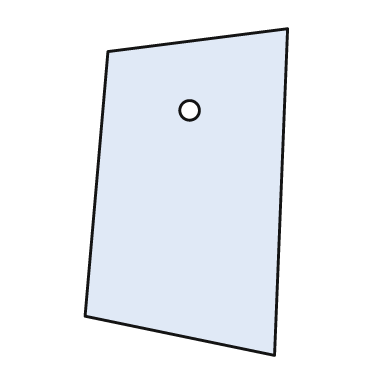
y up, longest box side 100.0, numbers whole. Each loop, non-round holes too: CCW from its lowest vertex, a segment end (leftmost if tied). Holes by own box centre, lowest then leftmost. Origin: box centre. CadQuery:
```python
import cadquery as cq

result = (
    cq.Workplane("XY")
    .moveTo(27.0, -50.0)
    .lineTo(31.0, 50.0)
    .lineTo(-24.0, 43.0)
    .lineTo(-31.0, -38.0)
    .close()
    .moveTo(1.0, 25.0)
    .circle(3.0)
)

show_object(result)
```